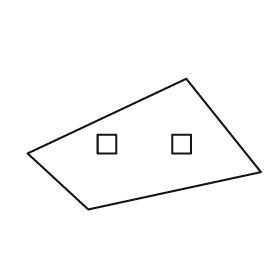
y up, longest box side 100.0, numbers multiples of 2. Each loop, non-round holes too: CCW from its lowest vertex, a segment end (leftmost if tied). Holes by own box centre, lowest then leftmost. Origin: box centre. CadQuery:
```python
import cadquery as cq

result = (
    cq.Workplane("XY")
    .moveTo(-24.0, -28.0)
    .lineTo(50.0, -12.0)
    .lineTo(18.0, 28.0)
    .lineTo(-50.0, -4.0)
    .close()
    .moveTo(-20.0, -4.0)
    .lineTo(-12.0, -4.0)
    .lineTo(-12.0, 4.0)
    .lineTo(-20.0, 4.0)
    .close()
    .moveTo(12.0, -4.0)
    .lineTo(20.0, -4.0)
    .lineTo(20.0, 4.0)
    .lineTo(12.0, 4.0)
    .close()
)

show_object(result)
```